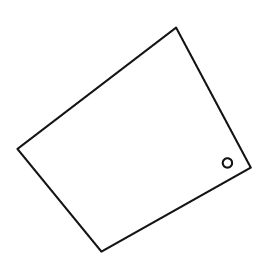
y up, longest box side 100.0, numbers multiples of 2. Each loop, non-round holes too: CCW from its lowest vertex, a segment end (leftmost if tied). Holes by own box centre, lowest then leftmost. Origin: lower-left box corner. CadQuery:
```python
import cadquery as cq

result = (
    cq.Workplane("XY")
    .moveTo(36.0, 0.0)
    .lineTo(100.0, 36.0)
    .lineTo(68.0, 96.0)
    .lineTo(0.0, 44.0)
    .close()
    .moveTo(90.0, 38.0)
    .circle(2.0)
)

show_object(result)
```